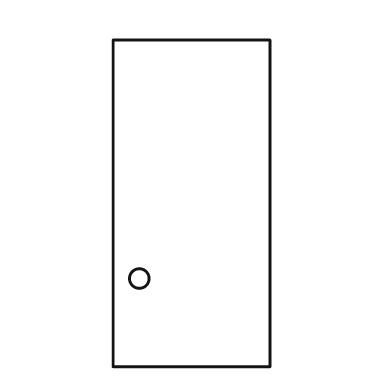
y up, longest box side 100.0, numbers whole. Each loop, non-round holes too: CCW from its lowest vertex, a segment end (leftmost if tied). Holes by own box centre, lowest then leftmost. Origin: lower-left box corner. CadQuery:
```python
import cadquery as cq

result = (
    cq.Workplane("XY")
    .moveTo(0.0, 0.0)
    .lineTo(48.0, 0.0)
    .lineTo(48.0, 100.0)
    .lineTo(0.0, 100.0)
    .close()
    .moveTo(8.0, 27.0)
    .circle(3.0)
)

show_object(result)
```